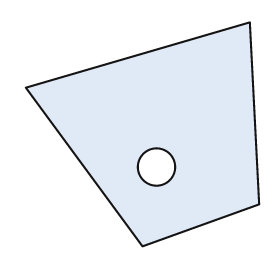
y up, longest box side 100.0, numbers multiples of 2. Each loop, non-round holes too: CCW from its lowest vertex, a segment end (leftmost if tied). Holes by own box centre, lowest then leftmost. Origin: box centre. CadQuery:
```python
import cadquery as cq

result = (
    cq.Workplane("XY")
    .moveTo(0.0, -48.0)
    .lineTo(50.0, -30.0)
    .lineTo(46.0, 48.0)
    .lineTo(-50.0, 20.0)
    .close()
    .moveTo(6.0, -14.0)
    .circle(8.0)
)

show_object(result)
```